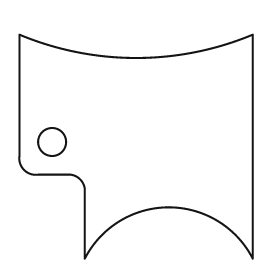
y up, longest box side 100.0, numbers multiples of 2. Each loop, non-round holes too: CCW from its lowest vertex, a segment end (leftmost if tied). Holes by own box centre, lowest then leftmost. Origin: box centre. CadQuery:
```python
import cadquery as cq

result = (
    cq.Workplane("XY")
    .moveTo(-22.0, -48.0)
    .threePointArc((14.0, -26.0), (50.0, -48.0))
    .lineTo(50.0, 48.0)
    .threePointArc((0.0, 38.0), (-50.0, 48.0))
    .lineTo(-50.0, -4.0)
    .threePointArc((-48.0, -10.0), (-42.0, -12.0))
    .lineTo(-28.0, -12.0)
    .threePointArc((-24.0, -14.0), (-22.0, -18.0))
    .close()
    .moveTo(-36.0, 2.0)
    .circle(6.0)
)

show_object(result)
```